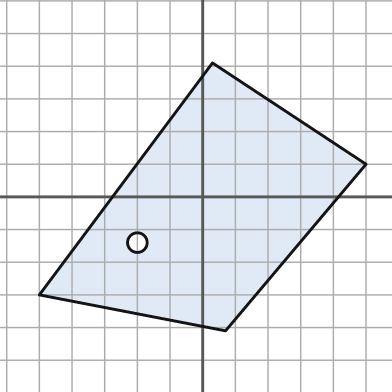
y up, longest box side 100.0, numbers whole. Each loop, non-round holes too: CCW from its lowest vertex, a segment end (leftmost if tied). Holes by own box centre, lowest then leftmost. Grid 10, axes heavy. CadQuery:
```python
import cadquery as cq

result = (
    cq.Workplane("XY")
    .moveTo(7.0, -41.0)
    .lineTo(50.0, 10.0)
    .lineTo(3.0, 41.0)
    .lineTo(-50.0, -30.0)
    .close()
    .moveTo(-20.0, -14.0)
    .circle(3.0)
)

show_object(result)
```